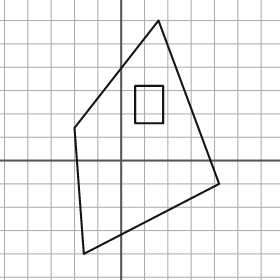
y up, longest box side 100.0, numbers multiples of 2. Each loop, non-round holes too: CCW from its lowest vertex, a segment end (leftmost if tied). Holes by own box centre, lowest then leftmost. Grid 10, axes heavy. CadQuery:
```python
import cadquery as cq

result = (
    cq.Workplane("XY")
    .moveTo(-16.0, -40.0)
    .lineTo(42.0, -10.0)
    .lineTo(16.0, 60.0)
    .lineTo(-20.0, 14.0)
    .close()
    .moveTo(6.0, 16.0)
    .lineTo(18.0, 16.0)
    .lineTo(18.0, 32.0)
    .lineTo(6.0, 32.0)
    .close()
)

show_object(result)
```